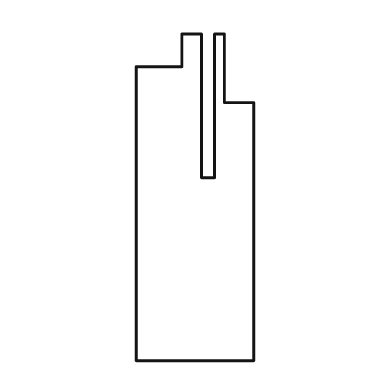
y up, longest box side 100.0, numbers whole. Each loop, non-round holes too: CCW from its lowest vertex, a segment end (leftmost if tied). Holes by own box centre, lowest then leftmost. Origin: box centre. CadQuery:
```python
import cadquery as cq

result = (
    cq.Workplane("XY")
    .moveTo(-18.0, -50.0)
    .lineTo(18.0, -50.0)
    .lineTo(18.0, 29.0)
    .lineTo(9.0, 29.0)
    .lineTo(9.0, 50.0)
    .lineTo(6.0, 50.0)
    .lineTo(6.0, 6.0)
    .lineTo(2.0, 6.0)
    .lineTo(2.0, 50.0)
    .lineTo(-4.0, 50.0)
    .lineTo(-4.0, 40.0)
    .lineTo(-18.0, 40.0)
    .close()
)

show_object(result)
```